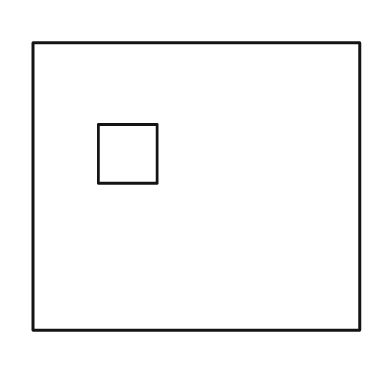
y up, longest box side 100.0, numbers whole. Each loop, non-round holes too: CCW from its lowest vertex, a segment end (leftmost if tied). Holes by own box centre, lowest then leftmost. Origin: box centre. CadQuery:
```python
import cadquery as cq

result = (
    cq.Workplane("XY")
    .moveTo(-50.0, -44.0)
    .lineTo(50.0, -44.0)
    .lineTo(50.0, 44.0)
    .lineTo(-50.0, 44.0)
    .close()
    .moveTo(-30.0, 1.0)
    .lineTo(-12.0, 1.0)
    .lineTo(-12.0, 19.0)
    .lineTo(-30.0, 19.0)
    .close()
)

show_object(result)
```